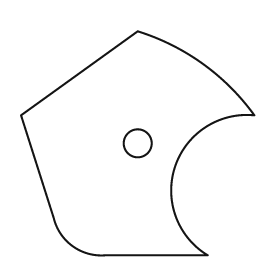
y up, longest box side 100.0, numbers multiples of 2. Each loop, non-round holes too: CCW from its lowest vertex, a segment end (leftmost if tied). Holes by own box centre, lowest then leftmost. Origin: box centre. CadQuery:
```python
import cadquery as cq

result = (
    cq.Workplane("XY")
    .moveTo(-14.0, -48.0)
    .lineTo(30.0, -48.0)
    .threePointArc((16.0, -10.0), (50.0, 12.0))
    .threePointArc((28.0, 34.0), (0.0, 48.0))
    .lineTo(-50.0, 12.0)
    .lineTo(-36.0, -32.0)
    .threePointArc((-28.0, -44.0), (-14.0, -48.0))
    .close()
    .moveTo(0.0, 0.0)
    .circle(6.0)
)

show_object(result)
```